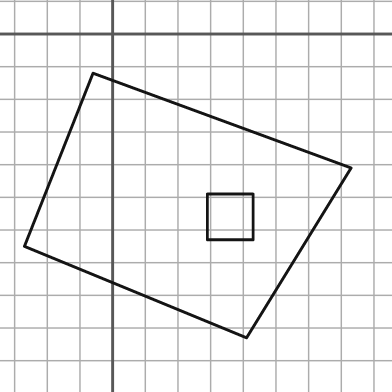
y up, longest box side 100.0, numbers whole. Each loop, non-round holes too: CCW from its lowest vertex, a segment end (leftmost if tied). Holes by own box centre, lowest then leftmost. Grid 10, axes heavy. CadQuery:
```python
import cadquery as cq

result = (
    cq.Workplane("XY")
    .moveTo(41.0, -93.0)
    .lineTo(73.0, -41.0)
    .lineTo(-6.0, -12.0)
    .lineTo(-27.0, -65.0)
    .close()
    .moveTo(29.0, -63.0)
    .lineTo(43.0, -63.0)
    .lineTo(43.0, -49.0)
    .lineTo(29.0, -49.0)
    .close()
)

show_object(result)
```